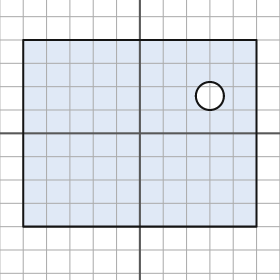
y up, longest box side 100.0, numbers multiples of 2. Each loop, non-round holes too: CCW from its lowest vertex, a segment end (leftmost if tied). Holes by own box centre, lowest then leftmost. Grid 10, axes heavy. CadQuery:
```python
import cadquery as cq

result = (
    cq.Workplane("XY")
    .moveTo(-50.0, -40.0)
    .lineTo(50.0, -40.0)
    .lineTo(50.0, 40.0)
    .lineTo(-50.0, 40.0)
    .close()
    .moveTo(30.0, 16.0)
    .circle(6.0)
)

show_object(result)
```